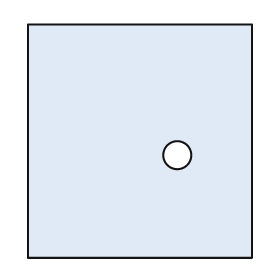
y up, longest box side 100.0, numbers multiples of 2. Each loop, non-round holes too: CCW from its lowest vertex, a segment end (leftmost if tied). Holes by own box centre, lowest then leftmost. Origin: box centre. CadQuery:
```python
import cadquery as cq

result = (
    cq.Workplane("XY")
    .moveTo(-48.0, -50.0)
    .lineTo(48.0, -50.0)
    .lineTo(48.0, 50.0)
    .lineTo(-48.0, 50.0)
    .close()
    .moveTo(16.0, -6.0)
    .circle(6.0)
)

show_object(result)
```